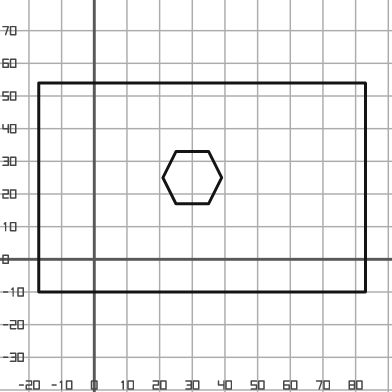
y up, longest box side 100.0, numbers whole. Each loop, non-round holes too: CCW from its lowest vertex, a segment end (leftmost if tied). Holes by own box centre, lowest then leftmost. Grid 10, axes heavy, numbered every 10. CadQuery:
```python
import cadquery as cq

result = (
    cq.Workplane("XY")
    .moveTo(-17.0, -10.0)
    .lineTo(83.0, -10.0)
    .lineTo(83.0, 54.0)
    .lineTo(-17.0, 54.0)
    .close()
    .moveTo(25.0, 17.0)
    .lineTo(35.0, 17.0)
    .lineTo(39.0, 25.0)
    .lineTo(35.0, 33.0)
    .lineTo(25.0, 33.0)
    .lineTo(21.0, 25.0)
    .close()
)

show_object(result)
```